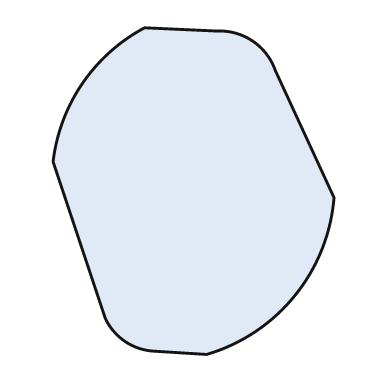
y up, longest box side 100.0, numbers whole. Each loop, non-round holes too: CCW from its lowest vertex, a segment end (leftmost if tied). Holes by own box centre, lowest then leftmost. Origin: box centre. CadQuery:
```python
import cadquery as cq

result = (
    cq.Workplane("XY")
    .moveTo(4.0, -50.0)
    .threePointArc((31.0, -32.0), (43.0, -2.0))
    .lineTo(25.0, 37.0)
    .threePointArc((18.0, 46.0), (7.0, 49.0))
    .lineTo(-15.0, 50.0)
    .threePointArc((-34.0, 33.0), (-43.0, 9.0))
    .lineTo(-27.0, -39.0)
    .threePointArc((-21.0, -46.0), (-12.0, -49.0))
    .close()
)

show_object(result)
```